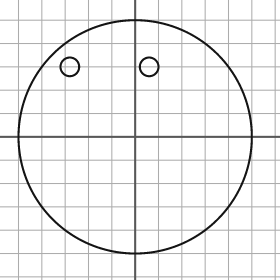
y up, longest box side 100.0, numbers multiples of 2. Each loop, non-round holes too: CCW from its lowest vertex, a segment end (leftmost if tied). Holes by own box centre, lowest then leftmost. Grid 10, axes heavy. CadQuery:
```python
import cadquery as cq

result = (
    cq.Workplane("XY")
    .moveTo(0.0, 0.0)
    .circle(50.0)
    .moveTo(-28.0, 30.0)
    .circle(4.0)
    .moveTo(6.0, 30.0)
    .circle(4.0)
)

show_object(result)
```